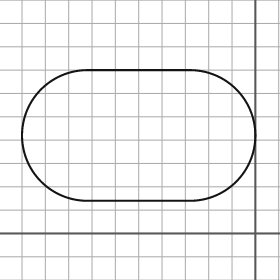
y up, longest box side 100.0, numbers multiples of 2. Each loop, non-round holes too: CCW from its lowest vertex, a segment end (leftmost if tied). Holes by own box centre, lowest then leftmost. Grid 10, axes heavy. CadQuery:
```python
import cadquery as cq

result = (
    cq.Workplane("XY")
    .moveTo(-72.0, 14.0)
    .lineTo(-28.0, 14.0)
    .threePointArc((0.0, 42.0), (-28.0, 70.0))
    .lineTo(-72.0, 70.0)
    .threePointArc((-100.0, 42.0), (-72.0, 14.0))
    .close()
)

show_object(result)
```